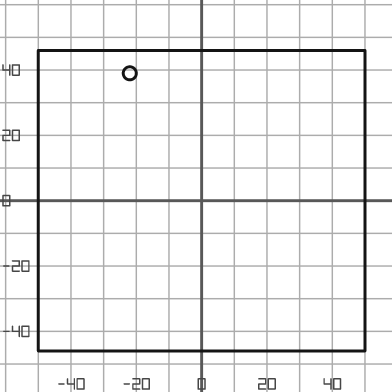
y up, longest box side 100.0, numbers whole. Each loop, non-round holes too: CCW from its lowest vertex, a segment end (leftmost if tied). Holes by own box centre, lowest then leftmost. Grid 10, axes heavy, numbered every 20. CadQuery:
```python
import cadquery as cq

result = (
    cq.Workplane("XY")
    .moveTo(-50.0, -46.0)
    .lineTo(50.0, -46.0)
    .lineTo(50.0, 46.0)
    .lineTo(-50.0, 46.0)
    .close()
    .moveTo(-22.0, 39.0)
    .circle(2.0)
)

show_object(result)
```